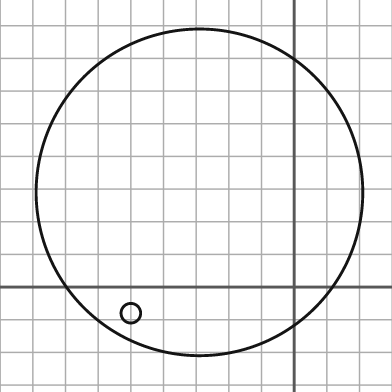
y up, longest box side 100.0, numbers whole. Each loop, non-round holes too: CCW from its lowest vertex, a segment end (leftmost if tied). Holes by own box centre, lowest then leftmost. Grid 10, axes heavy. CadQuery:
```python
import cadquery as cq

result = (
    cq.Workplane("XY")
    .moveTo(-29.0, 29.0)
    .circle(50.0)
    .moveTo(-50.0, -8.0)
    .circle(3.0)
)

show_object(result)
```